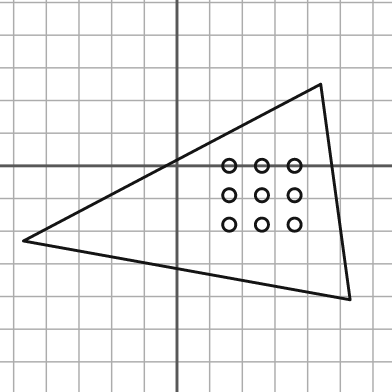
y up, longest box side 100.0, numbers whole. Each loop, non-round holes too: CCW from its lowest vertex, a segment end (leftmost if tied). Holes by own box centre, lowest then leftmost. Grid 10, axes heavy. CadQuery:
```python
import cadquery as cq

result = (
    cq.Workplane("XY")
    .moveTo(53.0, -41.0)
    .lineTo(44.0, 25.0)
    .lineTo(-47.0, -23.0)
    .close()
    .moveTo(16.0, -18.0)
    .circle(2.0)
    .moveTo(26.0, -18.0)
    .circle(2.0)
    .moveTo(36.0, -18.0)
    .circle(2.0)
    .moveTo(16.0, -9.0)
    .circle(2.0)
    .moveTo(26.0, -9.0)
    .circle(2.0)
    .moveTo(36.0, -9.0)
    .circle(2.0)
    .moveTo(16.0, 0.0)
    .circle(2.0)
    .moveTo(26.0, 0.0)
    .circle(2.0)
    .moveTo(36.0, 0.0)
    .circle(2.0)
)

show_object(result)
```